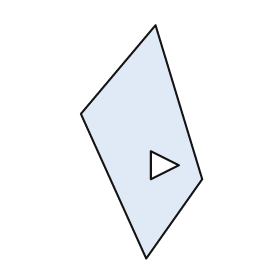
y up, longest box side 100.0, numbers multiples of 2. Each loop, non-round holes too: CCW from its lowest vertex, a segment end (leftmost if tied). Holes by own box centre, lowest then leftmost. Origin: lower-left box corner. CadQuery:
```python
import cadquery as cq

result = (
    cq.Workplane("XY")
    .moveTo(28.0, 0.0)
    .lineTo(52.0, 34.0)
    .lineTo(32.0, 100.0)
    .lineTo(0.0, 62.0)
    .close()
    .moveTo(30.0, 34.0)
    .lineTo(42.0, 40.0)
    .lineTo(30.0, 46.0)
    .close()
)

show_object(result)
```